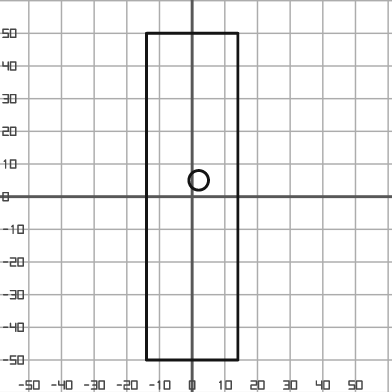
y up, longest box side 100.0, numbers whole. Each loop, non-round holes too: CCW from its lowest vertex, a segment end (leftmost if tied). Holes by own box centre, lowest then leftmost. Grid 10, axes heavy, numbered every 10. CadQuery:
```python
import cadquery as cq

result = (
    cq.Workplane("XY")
    .moveTo(-14.0, -50.0)
    .lineTo(14.0, -50.0)
    .lineTo(14.0, 50.0)
    .lineTo(-14.0, 50.0)
    .close()
    .moveTo(2.0, 5.0)
    .circle(3.0)
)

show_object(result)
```